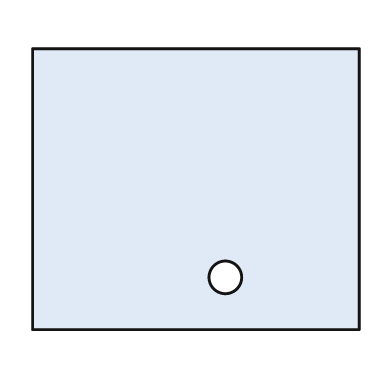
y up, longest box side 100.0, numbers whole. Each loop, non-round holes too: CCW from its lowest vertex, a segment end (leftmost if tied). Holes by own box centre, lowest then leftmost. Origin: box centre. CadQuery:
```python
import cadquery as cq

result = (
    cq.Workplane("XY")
    .moveTo(-50.0, -43.0)
    .lineTo(50.0, -43.0)
    .lineTo(50.0, 43.0)
    .lineTo(-50.0, 43.0)
    .close()
    .moveTo(9.0, -27.0)
    .circle(5.0)
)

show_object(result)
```